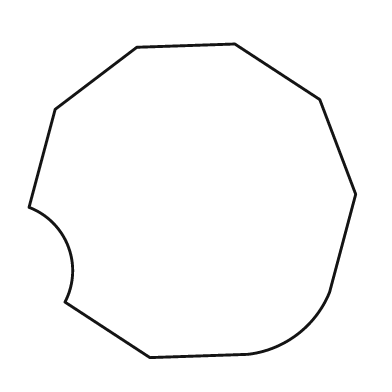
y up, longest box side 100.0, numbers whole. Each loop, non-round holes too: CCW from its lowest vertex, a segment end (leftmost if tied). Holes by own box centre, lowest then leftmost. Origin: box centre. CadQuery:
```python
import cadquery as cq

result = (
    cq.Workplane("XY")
    .moveTo(-13.0, -48.0)
    .lineTo(17.0, -47.0)
    .threePointArc((32.0, -41.0), (42.0, -28.0))
    .lineTo(50.0, 2.0)
    .lineTo(39.0, 31.0)
    .lineTo(13.0, 48.0)
    .lineTo(-17.0, 47.0)
    .lineTo(-42.0, 28.0)
    .lineTo(-50.0, -2.0)
    .threePointArc((-38.0, -14.0), (-39.0, -31.0))
    .close()
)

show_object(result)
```